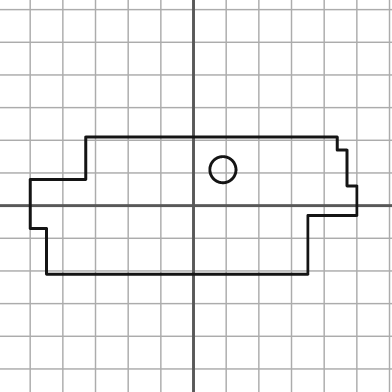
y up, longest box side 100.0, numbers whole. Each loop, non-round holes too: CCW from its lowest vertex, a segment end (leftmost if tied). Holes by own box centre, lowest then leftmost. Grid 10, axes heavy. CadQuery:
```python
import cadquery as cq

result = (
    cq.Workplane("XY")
    .moveTo(-45.0, -21.0)
    .lineTo(35.0, -21.0)
    .lineTo(35.0, -3.0)
    .lineTo(50.0, -3.0)
    .lineTo(50.0, 6.0)
    .lineTo(47.0, 6.0)
    .lineTo(47.0, 17.0)
    .lineTo(44.0, 17.0)
    .lineTo(44.0, 21.0)
    .lineTo(-33.0, 21.0)
    .lineTo(-33.0, 8.0)
    .lineTo(-50.0, 8.0)
    .lineTo(-50.0, -7.0)
    .lineTo(-45.0, -7.0)
    .close()
    .moveTo(9.0, 11.0)
    .circle(4.0)
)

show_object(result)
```